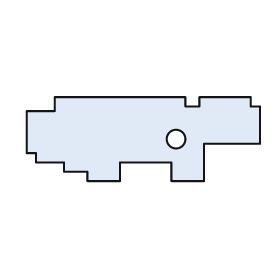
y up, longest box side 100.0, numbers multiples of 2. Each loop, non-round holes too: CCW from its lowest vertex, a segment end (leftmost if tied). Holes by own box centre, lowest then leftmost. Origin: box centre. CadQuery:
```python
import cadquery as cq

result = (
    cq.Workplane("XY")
    .moveTo(-24.0, -18.0)
    .lineTo(-10.0, -18.0)
    .lineTo(-10.0, -10.0)
    .lineTo(12.0, -10.0)
    .lineTo(12.0, -18.0)
    .lineTo(26.0, -18.0)
    .lineTo(26.0, -2.0)
    .lineTo(50.0, -2.0)
    .lineTo(50.0, 14.0)
    .lineTo(46.0, 14.0)
    .lineTo(46.0, 18.0)
    .lineTo(24.0, 18.0)
    .lineTo(24.0, 14.0)
    .lineTo(18.0, 14.0)
    .lineTo(18.0, 18.0)
    .lineTo(-38.0, 18.0)
    .lineTo(-38.0, 12.0)
    .lineTo(-50.0, 12.0)
    .lineTo(-50.0, -6.0)
    .lineTo(-46.0, -6.0)
    .lineTo(-46.0, -10.0)
    .lineTo(-34.0, -10.0)
    .lineTo(-34.0, -14.0)
    .lineTo(-24.0, -14.0)
    .close()
    .moveTo(14.0, 0.0)
    .circle(4.0)
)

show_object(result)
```